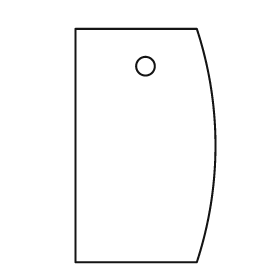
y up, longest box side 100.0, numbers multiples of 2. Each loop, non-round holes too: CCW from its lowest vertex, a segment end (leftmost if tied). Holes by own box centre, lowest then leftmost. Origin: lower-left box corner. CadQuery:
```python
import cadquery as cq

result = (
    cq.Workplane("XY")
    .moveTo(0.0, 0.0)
    .lineTo(52.0, 0.0)
    .threePointArc((60.0, 50.0), (52.0, 100.0))
    .lineTo(0.0, 100.0)
    .close()
    .moveTo(30.0, 84.0)
    .circle(4.0)
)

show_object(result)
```